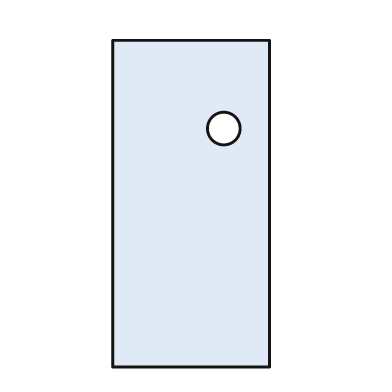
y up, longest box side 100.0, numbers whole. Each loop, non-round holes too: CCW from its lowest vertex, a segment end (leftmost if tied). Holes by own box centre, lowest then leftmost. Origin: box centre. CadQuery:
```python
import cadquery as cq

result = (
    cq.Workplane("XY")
    .moveTo(-24.0, -50.0)
    .lineTo(24.0, -50.0)
    .lineTo(24.0, 50.0)
    .lineTo(-24.0, 50.0)
    .close()
    .moveTo(10.0, 23.0)
    .circle(5.0)
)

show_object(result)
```